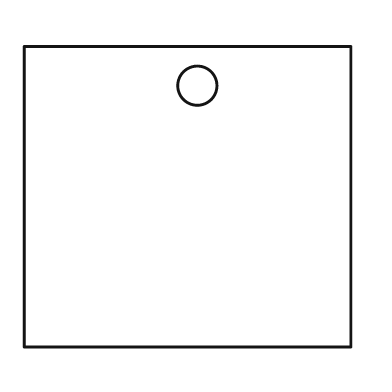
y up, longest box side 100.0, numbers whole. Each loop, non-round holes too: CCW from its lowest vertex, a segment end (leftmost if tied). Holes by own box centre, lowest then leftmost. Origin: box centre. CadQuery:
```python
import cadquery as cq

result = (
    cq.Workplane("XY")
    .moveTo(-50.0, -46.0)
    .lineTo(50.0, -46.0)
    .lineTo(50.0, 46.0)
    .lineTo(-50.0, 46.0)
    .close()
    .moveTo(3.0, 34.0)
    .circle(6.0)
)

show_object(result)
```